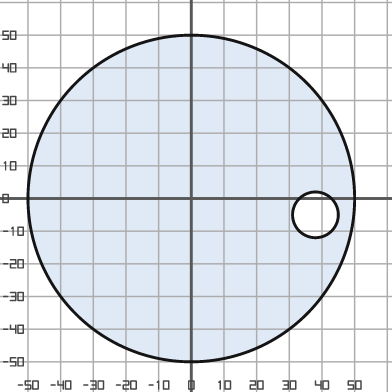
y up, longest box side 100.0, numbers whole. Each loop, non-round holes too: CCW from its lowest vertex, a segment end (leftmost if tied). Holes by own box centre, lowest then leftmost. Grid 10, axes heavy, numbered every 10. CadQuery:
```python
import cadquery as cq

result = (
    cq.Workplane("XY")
    .moveTo(0.0, 0.0)
    .circle(50.0)
    .moveTo(38.0, -5.0)
    .circle(7.0)
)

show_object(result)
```